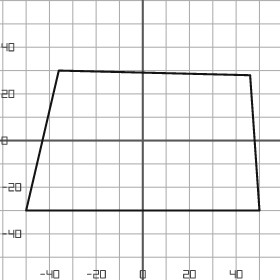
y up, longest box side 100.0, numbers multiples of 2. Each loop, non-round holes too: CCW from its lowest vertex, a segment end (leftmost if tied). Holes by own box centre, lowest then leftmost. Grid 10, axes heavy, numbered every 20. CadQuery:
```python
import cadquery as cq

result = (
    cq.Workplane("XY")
    .moveTo(-50.0, -30.0)
    .lineTo(50.0, -30.0)
    .lineTo(46.0, 28.0)
    .lineTo(-36.0, 30.0)
    .close()
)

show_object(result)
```